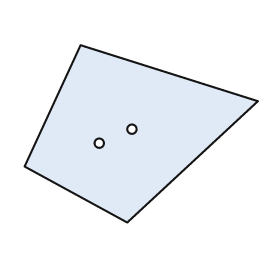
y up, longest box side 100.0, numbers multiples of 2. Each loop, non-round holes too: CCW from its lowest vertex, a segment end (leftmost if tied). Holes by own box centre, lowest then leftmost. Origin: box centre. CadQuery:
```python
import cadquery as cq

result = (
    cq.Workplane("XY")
    .moveTo(-6.0, -38.0)
    .lineTo(50.0, 14.0)
    .lineTo(-26.0, 38.0)
    .lineTo(-50.0, -14.0)
    .close()
    .moveTo(-18.0, -4.0)
    .circle(2.0)
    .moveTo(-4.0, 2.0)
    .circle(2.0)
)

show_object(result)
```